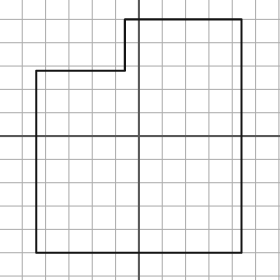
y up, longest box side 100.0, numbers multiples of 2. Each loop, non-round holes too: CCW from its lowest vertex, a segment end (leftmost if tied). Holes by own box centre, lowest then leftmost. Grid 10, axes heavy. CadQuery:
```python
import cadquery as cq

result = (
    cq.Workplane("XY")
    .moveTo(-44.0, -50.0)
    .lineTo(44.0, -50.0)
    .lineTo(44.0, 50.0)
    .lineTo(-6.0, 50.0)
    .lineTo(-6.0, 28.0)
    .lineTo(-44.0, 28.0)
    .close()
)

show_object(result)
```